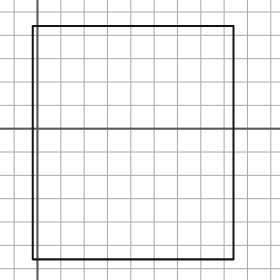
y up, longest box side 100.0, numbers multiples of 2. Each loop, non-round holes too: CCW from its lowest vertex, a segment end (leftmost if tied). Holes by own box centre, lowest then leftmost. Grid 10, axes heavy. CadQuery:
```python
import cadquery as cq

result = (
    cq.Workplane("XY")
    .moveTo(-2.0, -56.0)
    .lineTo(84.0, -56.0)
    .lineTo(84.0, 44.0)
    .lineTo(-2.0, 44.0)
    .close()
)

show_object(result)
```